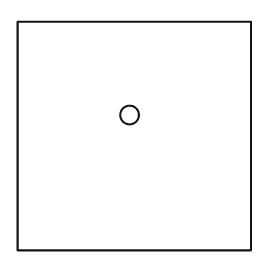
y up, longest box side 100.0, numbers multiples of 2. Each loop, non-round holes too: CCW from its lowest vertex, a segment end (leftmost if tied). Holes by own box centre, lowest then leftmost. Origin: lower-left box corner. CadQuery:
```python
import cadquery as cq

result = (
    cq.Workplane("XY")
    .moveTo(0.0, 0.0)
    .lineTo(100.0, 0.0)
    .lineTo(100.0, 98.0)
    .lineTo(0.0, 98.0)
    .close()
    .moveTo(48.0, 58.0)
    .circle(4.0)
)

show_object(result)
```